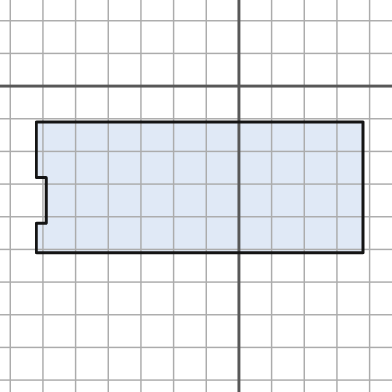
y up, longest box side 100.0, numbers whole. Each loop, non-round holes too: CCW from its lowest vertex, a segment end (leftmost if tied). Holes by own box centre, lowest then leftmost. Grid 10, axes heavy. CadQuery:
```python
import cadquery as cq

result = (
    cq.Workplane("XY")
    .moveTo(-62.0, -51.0)
    .lineTo(38.0, -51.0)
    .lineTo(38.0, -11.0)
    .lineTo(-62.0, -11.0)
    .lineTo(-62.0, -28.0)
    .lineTo(-59.0, -28.0)
    .lineTo(-59.0, -42.0)
    .lineTo(-62.0, -42.0)
    .close()
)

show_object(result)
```